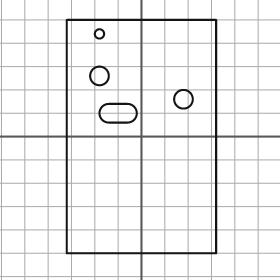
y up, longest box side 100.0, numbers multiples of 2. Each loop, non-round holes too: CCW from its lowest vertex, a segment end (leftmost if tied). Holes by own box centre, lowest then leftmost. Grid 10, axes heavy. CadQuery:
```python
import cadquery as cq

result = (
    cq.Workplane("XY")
    .moveTo(-32.0, -50.0)
    .lineTo(32.0, -50.0)
    .lineTo(32.0, 50.0)
    .lineTo(-32.0, 50.0)
    .close()
    .moveTo(-14.0, 6.0)
    .lineTo(-6.0, 6.0)
    .threePointArc((-2.0, 10.0), (-6.0, 14.0))
    .lineTo(-14.0, 14.0)
    .threePointArc((-18.0, 10.0), (-14.0, 6.0))
    .close()
    .moveTo(18.0, 16.0)
    .circle(4.0)
    .moveTo(-18.0, 26.0)
    .circle(4.0)
    .moveTo(-18.0, 44.0)
    .circle(2.0)
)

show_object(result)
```